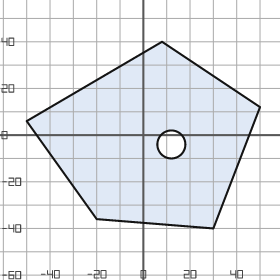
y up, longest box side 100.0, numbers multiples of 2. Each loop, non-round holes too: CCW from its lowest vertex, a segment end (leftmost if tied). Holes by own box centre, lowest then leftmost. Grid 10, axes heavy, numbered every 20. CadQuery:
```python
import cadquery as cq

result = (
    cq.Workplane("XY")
    .moveTo(30.0, -40.0)
    .lineTo(50.0, 12.0)
    .lineTo(8.0, 40.0)
    .lineTo(-50.0, 6.0)
    .lineTo(-20.0, -36.0)
    .close()
    .moveTo(12.0, -4.0)
    .circle(6.0)
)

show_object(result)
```